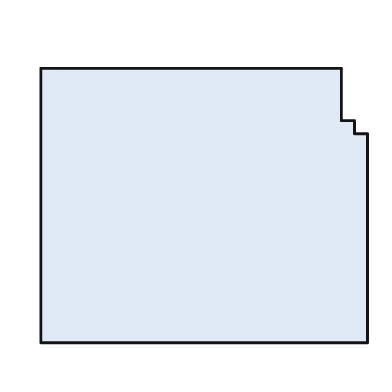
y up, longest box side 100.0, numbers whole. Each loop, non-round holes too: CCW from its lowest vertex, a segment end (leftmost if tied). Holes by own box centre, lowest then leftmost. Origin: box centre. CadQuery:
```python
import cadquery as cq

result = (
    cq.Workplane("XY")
    .moveTo(-50.0, -42.0)
    .lineTo(50.0, -42.0)
    .lineTo(50.0, 22.0)
    .lineTo(46.0, 22.0)
    .lineTo(46.0, 26.0)
    .lineTo(42.0, 26.0)
    .lineTo(42.0, 42.0)
    .lineTo(-50.0, 42.0)
    .close()
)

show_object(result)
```